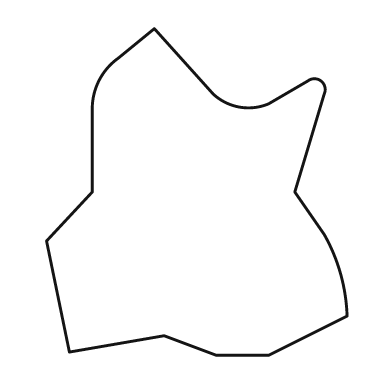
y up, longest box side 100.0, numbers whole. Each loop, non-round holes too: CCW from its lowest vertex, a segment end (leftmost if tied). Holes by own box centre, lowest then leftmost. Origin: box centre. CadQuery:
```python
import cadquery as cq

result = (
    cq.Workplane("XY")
    .moveTo(6.0, -50.0)
    .lineTo(22.0, -50.0)
    .lineTo(46.0, -38.0)
    .threePointArc((44.0, -25.0), (39.0, -13.0))
    .lineTo(30.0, 0.0)
    .lineTo(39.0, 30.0)
    .threePointArc((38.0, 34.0), (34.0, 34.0))
    .lineTo(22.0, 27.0)
    .threePointArc((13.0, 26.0), (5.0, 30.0))
    .lineTo(-13.0, 50.0)
    .lineTo(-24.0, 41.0)
    .threePointArc((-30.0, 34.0), (-32.0, 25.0))
    .lineTo(-32.0, 0.0)
    .lineTo(-46.0, -15.0)
    .lineTo(-39.0, -49.0)
    .lineTo(-10.0, -44.0)
    .close()
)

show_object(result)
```